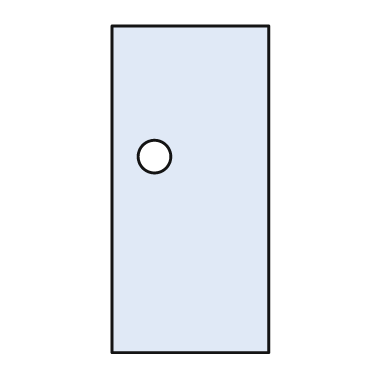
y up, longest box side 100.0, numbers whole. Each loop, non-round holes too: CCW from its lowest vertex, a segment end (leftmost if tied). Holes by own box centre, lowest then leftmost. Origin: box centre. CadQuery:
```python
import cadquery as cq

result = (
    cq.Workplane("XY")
    .moveTo(-24.0, -50.0)
    .lineTo(24.0, -50.0)
    .lineTo(24.0, 50.0)
    .lineTo(-24.0, 50.0)
    .close()
    .moveTo(-11.0, 10.0)
    .circle(5.0)
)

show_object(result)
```